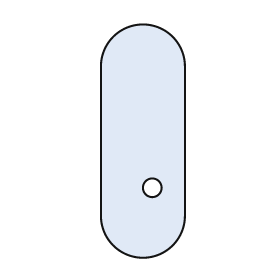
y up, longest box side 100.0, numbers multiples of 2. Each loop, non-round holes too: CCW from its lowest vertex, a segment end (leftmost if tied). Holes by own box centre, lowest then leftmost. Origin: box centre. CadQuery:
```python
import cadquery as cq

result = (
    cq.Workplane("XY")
    .moveTo(-18.0, -32.0)
    .threePointArc((0.0, -50.0), (18.0, -32.0))
    .lineTo(18.0, 32.0)
    .threePointArc((0.0, 50.0), (-18.0, 32.0))
    .close()
    .moveTo(4.0, -20.0)
    .circle(4.0)
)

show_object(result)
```